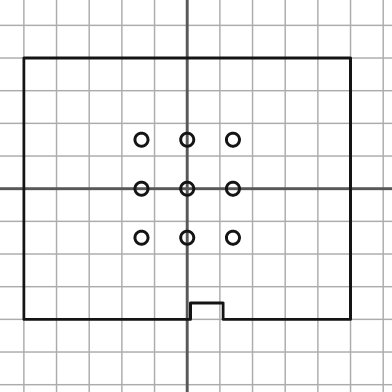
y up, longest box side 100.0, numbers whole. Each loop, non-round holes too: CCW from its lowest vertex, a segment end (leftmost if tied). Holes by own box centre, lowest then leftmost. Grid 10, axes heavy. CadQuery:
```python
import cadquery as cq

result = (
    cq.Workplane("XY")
    .moveTo(-50.0, -40.0)
    .lineTo(1.0, -40.0)
    .lineTo(1.0, -35.0)
    .lineTo(11.0, -35.0)
    .lineTo(11.0, -40.0)
    .lineTo(50.0, -40.0)
    .lineTo(50.0, 40.0)
    .lineTo(-50.0, 40.0)
    .close()
    .moveTo(-14.0, -15.0)
    .circle(2.0)
    .moveTo(0.0, -15.0)
    .circle(2.0)
    .moveTo(14.0, -15.0)
    .circle(2.0)
    .moveTo(-14.0, 0.0)
    .circle(2.0)
    .moveTo(0.0, 0.0)
    .circle(2.0)
    .moveTo(14.0, 0.0)
    .circle(2.0)
    .moveTo(-14.0, 15.0)
    .circle(2.0)
    .moveTo(0.0, 15.0)
    .circle(2.0)
    .moveTo(14.0, 15.0)
    .circle(2.0)
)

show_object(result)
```